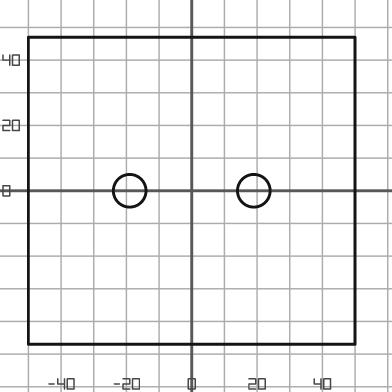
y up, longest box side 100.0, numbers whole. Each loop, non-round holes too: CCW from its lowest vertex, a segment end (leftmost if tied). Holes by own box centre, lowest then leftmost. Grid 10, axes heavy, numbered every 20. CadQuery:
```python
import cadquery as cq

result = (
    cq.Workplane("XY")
    .moveTo(-50.0, -47.0)
    .lineTo(50.0, -47.0)
    .lineTo(50.0, 47.0)
    .lineTo(-50.0, 47.0)
    .close()
    .moveTo(-19.0, 0.0)
    .circle(5.0)
    .moveTo(19.0, 0.0)
    .circle(5.0)
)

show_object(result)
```